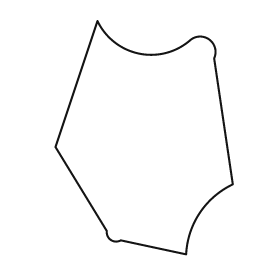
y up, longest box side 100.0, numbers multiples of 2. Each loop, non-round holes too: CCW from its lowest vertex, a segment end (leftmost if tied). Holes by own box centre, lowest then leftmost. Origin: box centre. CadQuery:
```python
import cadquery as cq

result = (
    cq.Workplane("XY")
    .moveTo(18.0, -50.0)
    .threePointArc((24.0, -32.0), (38.0, -20.0))
    .lineTo(30.0, 34.0)
    .threePointArc((28.0, 42.0), (20.0, 42.0))
    .threePointArc((-2.0, 36.0), (-20.0, 50.0))
    .lineTo(-38.0, -4.0)
    .lineTo(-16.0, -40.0)
    .threePointArc((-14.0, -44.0), (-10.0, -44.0))
    .close()
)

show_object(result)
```